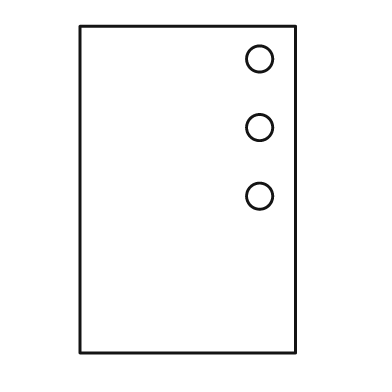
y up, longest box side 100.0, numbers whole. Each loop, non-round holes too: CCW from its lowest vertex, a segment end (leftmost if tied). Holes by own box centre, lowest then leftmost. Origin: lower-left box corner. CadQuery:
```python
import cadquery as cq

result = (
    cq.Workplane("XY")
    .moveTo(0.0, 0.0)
    .lineTo(66.0, 0.0)
    .lineTo(66.0, 100.0)
    .lineTo(0.0, 100.0)
    .close()
    .moveTo(55.0, 48.0)
    .circle(4.0)
    .moveTo(55.0, 69.0)
    .circle(4.0)
    .moveTo(55.0, 90.0)
    .circle(4.0)
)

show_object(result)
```